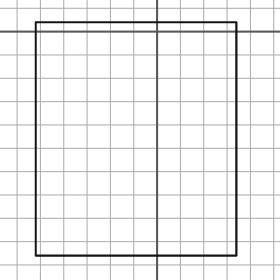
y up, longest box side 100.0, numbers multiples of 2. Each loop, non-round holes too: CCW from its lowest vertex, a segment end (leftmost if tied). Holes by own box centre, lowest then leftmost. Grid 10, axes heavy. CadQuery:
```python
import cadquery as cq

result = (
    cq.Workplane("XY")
    .moveTo(-52.0, -96.0)
    .lineTo(34.0, -96.0)
    .lineTo(34.0, 4.0)
    .lineTo(-52.0, 4.0)
    .close()
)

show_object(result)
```